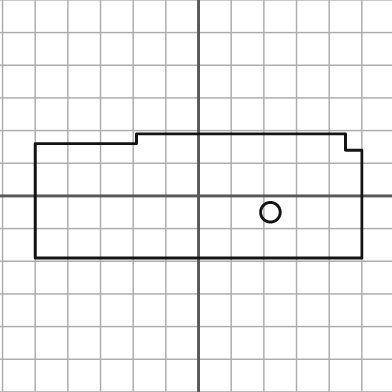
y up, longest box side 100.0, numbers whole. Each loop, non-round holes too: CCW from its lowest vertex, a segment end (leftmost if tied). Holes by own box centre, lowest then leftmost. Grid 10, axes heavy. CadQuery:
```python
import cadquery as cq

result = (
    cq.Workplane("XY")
    .moveTo(-50.0, -19.0)
    .lineTo(50.0, -19.0)
    .lineTo(50.0, 14.0)
    .lineTo(45.0, 14.0)
    .lineTo(45.0, 19.0)
    .lineTo(-19.0, 19.0)
    .lineTo(-19.0, 16.0)
    .lineTo(-50.0, 16.0)
    .close()
    .moveTo(22.0, -5.0)
    .circle(3.0)
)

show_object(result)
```